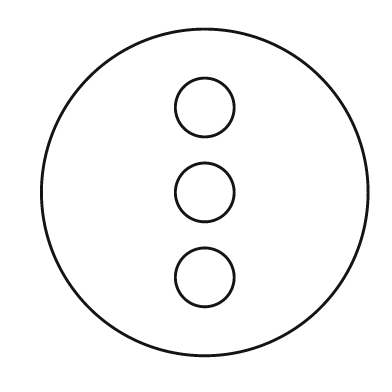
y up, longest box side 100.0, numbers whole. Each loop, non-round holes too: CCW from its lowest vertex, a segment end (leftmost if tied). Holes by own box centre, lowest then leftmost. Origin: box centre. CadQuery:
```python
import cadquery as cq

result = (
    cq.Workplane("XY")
    .moveTo(0.0, 0.0)
    .circle(50.0)
    .moveTo(0.0, -26.0)
    .circle(9.0)
    .moveTo(0.0, 0.0)
    .circle(9.0)
    .moveTo(0.0, 26.0)
    .circle(9.0)
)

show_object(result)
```